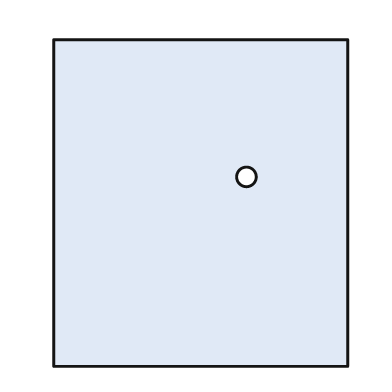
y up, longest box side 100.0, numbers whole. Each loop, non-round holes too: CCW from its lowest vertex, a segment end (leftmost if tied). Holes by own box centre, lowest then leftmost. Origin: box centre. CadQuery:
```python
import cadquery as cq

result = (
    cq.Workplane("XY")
    .moveTo(-45.0, -50.0)
    .lineTo(45.0, -50.0)
    .lineTo(45.0, 50.0)
    .lineTo(-45.0, 50.0)
    .close()
    .moveTo(14.0, 8.0)
    .circle(3.0)
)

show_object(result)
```